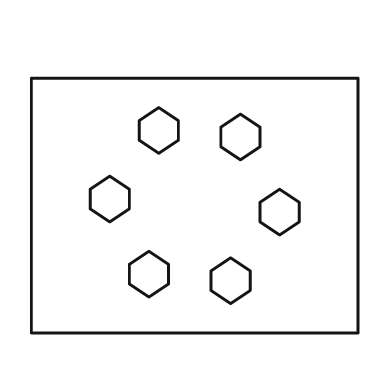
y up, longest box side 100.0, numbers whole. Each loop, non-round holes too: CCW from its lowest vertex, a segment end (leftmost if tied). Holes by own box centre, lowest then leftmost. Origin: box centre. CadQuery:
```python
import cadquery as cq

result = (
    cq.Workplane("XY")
    .moveTo(-50.0, -39.0)
    .lineTo(50.0, -39.0)
    .lineTo(50.0, 39.0)
    .lineTo(-50.0, 39.0)
    .close()
    .moveTo(11.0, -30.0)
    .lineTo(17.0, -26.0)
    .lineTo(17.0, -20.0)
    .lineTo(11.0, -16.0)
    .lineTo(5.0, -20.0)
    .lineTo(5.0, -26.0)
    .close()
    .moveTo(-14.0, -28.0)
    .lineTo(-8.0, -24.0)
    .lineTo(-8.0, -18.0)
    .lineTo(-14.0, -14.0)
    .lineTo(-20.0, -18.0)
    .lineTo(-20.0, -24.0)
    .close()
    .moveTo(26.0, -9.0)
    .lineTo(32.0, -5.0)
    .lineTo(32.0, 1.0)
    .lineTo(26.0, 5.0)
    .lineTo(20.0, 1.0)
    .lineTo(20.0, -5.0)
    .close()
    .moveTo(-26.0, -5.0)
    .lineTo(-20.0, -1.0)
    .lineTo(-20.0, 5.0)
    .lineTo(-26.0, 9.0)
    .lineTo(-32.0, 5.0)
    .lineTo(-32.0, -1.0)
    .close()
    .moveTo(14.0, 14.0)
    .lineTo(20.0, 18.0)
    .lineTo(20.0, 24.0)
    .lineTo(14.0, 28.0)
    .lineTo(8.0, 24.0)
    .lineTo(8.0, 18.0)
    .close()
    .moveTo(-11.0, 16.0)
    .lineTo(-5.0, 20.0)
    .lineTo(-5.0, 26.0)
    .lineTo(-11.0, 30.0)
    .lineTo(-17.0, 26.0)
    .lineTo(-17.0, 20.0)
    .close()
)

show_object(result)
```